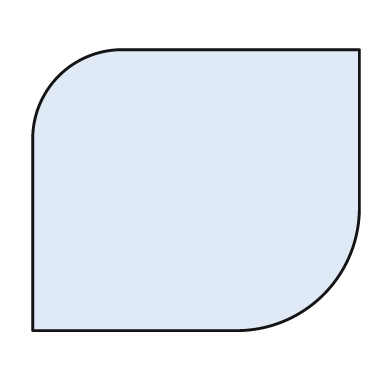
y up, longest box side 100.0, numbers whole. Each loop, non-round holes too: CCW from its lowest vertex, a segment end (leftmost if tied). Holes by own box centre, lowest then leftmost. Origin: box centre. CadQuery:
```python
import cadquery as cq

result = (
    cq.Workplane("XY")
    .moveTo(-50.0, -43.0)
    .lineTo(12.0, -43.0)
    .threePointArc((39.0, -32.0), (50.0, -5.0))
    .lineTo(50.0, 43.0)
    .lineTo(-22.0, 43.0)
    .threePointArc((-42.0, 35.0), (-50.0, 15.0))
    .close()
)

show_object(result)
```